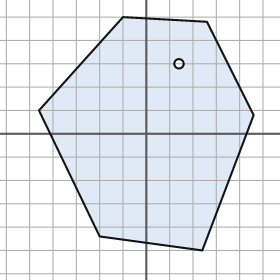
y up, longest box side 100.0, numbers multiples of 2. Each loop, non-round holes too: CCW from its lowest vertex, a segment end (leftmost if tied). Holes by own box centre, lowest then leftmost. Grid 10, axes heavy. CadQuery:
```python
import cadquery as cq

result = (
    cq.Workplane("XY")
    .moveTo(24.0, -50.0)
    .lineTo(46.0, 8.0)
    .lineTo(26.0, 48.0)
    .lineTo(-10.0, 50.0)
    .lineTo(-46.0, 10.0)
    .lineTo(-20.0, -44.0)
    .close()
    .moveTo(14.0, 30.0)
    .circle(2.0)
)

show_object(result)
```